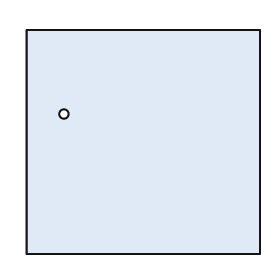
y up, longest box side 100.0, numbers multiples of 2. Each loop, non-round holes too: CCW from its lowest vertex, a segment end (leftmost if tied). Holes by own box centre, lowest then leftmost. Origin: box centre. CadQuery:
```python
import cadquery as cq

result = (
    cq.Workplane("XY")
    .moveTo(-50.0, -48.0)
    .lineTo(50.0, -48.0)
    .lineTo(50.0, 48.0)
    .lineTo(-50.0, 48.0)
    .close()
    .moveTo(-34.0, 12.0)
    .circle(2.0)
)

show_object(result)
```